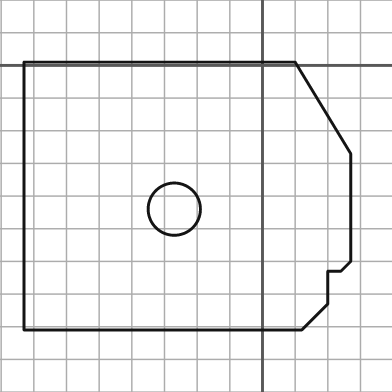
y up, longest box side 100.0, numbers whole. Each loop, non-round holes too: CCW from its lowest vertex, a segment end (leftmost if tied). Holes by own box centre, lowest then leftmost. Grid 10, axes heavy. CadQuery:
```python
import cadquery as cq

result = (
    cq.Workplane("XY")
    .moveTo(-73.0, -81.0)
    .lineTo(12.0, -81.0)
    .lineTo(20.0, -73.0)
    .lineTo(20.0, -63.0)
    .lineTo(24.0, -63.0)
    .lineTo(27.0, -60.0)
    .lineTo(27.0, -27.0)
    .lineTo(10.0, 1.0)
    .lineTo(-73.0, 1.0)
    .close()
    .moveTo(-27.0, -44.0)
    .circle(8.0)
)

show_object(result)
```